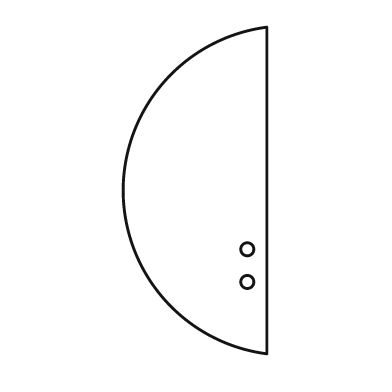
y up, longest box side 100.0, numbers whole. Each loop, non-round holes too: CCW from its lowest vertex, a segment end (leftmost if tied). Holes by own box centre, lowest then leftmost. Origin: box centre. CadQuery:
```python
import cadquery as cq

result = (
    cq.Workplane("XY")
    .moveTo(22.0, -50.0)
    .lineTo(22.0, 50.0)
    .threePointArc((-22.0, 0.0), (22.0, -50.0))
    .close()
    .moveTo(16.0, -28.0)
    .circle(2.0)
    .moveTo(16.0, -18.0)
    .circle(2.0)
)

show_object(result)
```